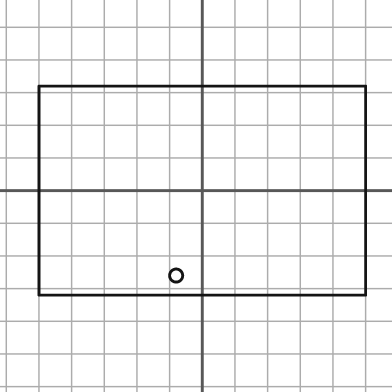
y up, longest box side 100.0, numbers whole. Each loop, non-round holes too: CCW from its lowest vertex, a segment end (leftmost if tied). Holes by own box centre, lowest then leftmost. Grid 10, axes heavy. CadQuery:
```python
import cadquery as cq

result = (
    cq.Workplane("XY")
    .moveTo(-50.0, -32.0)
    .lineTo(50.0, -32.0)
    .lineTo(50.0, 32.0)
    .lineTo(-50.0, 32.0)
    .close()
    .moveTo(-8.0, -26.0)
    .circle(2.0)
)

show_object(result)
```